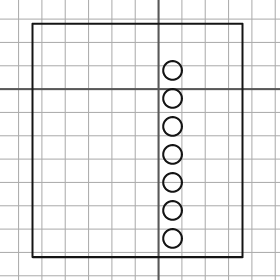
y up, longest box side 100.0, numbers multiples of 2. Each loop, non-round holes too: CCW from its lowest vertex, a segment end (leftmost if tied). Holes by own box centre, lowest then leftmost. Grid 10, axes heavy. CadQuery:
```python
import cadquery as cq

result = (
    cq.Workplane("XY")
    .moveTo(-54.0, -72.0)
    .lineTo(36.0, -72.0)
    .lineTo(36.0, 28.0)
    .lineTo(-54.0, 28.0)
    .close()
    .moveTo(6.0, -64.0)
    .circle(4.0)
    .moveTo(6.0, -52.0)
    .circle(4.0)
    .moveTo(6.0, -40.0)
    .circle(4.0)
    .moveTo(6.0, -28.0)
    .circle(4.0)
    .moveTo(6.0, -16.0)
    .circle(4.0)
    .moveTo(6.0, -4.0)
    .circle(4.0)
    .moveTo(6.0, 8.0)
    .circle(4.0)
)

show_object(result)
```